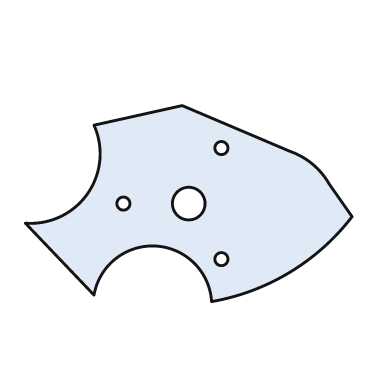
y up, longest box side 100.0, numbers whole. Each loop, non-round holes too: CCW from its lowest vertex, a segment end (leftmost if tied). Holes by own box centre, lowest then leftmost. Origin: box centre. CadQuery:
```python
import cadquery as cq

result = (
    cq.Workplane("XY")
    .moveTo(7.0, -30.0)
    .threePointArc((31.0, -21.0), (50.0, -4.0))
    .lineTo(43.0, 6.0)
    .threePointArc((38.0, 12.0), (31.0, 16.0))
    .lineTo(-2.0, 30.0)
    .lineTo(-29.0, 24.0)
    .threePointArc((-31.0, 3.0), (-50.0, -6.0))
    .lineTo(-29.0, -28.0)
    .threePointArc((-10.0, -13.0), (7.0, -30.0))
    .close()
    .moveTo(10.0, -17.0)
    .circle(2.0)
    .moveTo(-20.0, 0.0)
    .circle(2.0)
    .moveTo(0.0, 0.0)
    .circle(5.0)
    .moveTo(10.0, 17.0)
    .circle(2.0)
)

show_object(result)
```